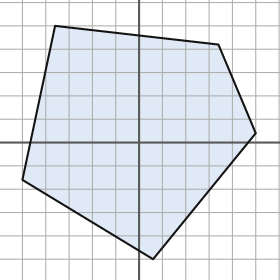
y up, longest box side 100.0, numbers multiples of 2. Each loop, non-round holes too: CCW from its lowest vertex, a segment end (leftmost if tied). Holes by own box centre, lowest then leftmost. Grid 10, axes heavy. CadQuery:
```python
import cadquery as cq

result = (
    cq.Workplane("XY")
    .moveTo(6.0, -50.0)
    .lineTo(50.0, 4.0)
    .lineTo(34.0, 42.0)
    .lineTo(-36.0, 50.0)
    .lineTo(-50.0, -16.0)
    .close()
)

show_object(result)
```